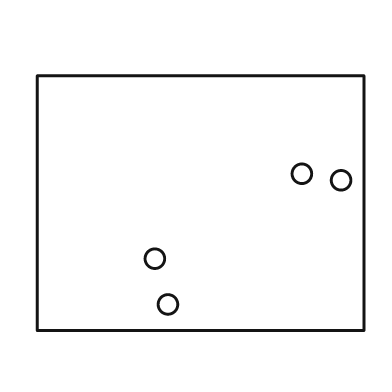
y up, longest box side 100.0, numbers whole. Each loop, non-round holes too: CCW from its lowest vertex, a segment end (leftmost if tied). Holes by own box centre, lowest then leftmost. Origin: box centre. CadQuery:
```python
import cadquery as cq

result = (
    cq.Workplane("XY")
    .moveTo(-50.0, -39.0)
    .lineTo(50.0, -39.0)
    .lineTo(50.0, 39.0)
    .lineTo(-50.0, 39.0)
    .close()
    .moveTo(-10.0, -31.0)
    .circle(3.0)
    .moveTo(-14.0, -17.0)
    .circle(3.0)
    .moveTo(43.0, 7.0)
    .circle(3.0)
    .moveTo(31.0, 9.0)
    .circle(3.0)
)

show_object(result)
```